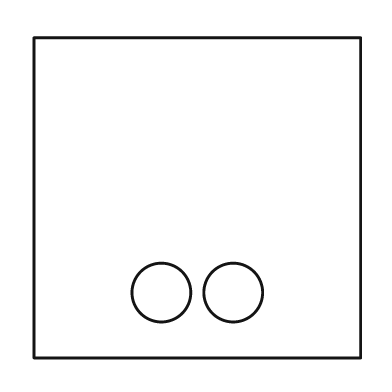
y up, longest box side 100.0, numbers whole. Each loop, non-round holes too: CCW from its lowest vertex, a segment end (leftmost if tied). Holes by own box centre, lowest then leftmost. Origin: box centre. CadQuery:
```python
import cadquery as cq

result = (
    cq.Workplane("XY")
    .moveTo(-50.0, -49.0)
    .lineTo(50.0, -49.0)
    .lineTo(50.0, 49.0)
    .lineTo(-50.0, 49.0)
    .close()
    .moveTo(-11.0, -29.0)
    .circle(9.0)
    .moveTo(11.0, -29.0)
    .circle(9.0)
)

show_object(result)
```